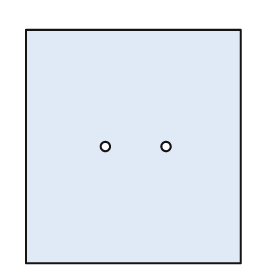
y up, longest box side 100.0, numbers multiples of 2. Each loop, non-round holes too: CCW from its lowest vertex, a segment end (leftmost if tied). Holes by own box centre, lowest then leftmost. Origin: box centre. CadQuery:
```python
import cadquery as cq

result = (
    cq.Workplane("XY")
    .moveTo(-46.0, -50.0)
    .lineTo(46.0, -50.0)
    .lineTo(46.0, 50.0)
    .lineTo(-46.0, 50.0)
    .close()
    .moveTo(-12.0, 0.0)
    .circle(2.0)
    .moveTo(14.0, 0.0)
    .circle(2.0)
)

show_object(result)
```